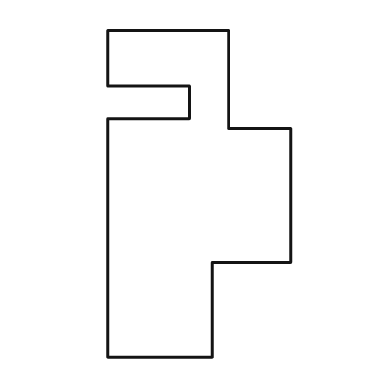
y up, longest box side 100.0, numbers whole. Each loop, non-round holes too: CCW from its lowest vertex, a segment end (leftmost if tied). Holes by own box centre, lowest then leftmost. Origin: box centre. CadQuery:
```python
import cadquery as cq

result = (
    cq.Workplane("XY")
    .moveTo(-28.0, -50.0)
    .lineTo(4.0, -50.0)
    .lineTo(4.0, -21.0)
    .lineTo(28.0, -21.0)
    .lineTo(28.0, 20.0)
    .lineTo(9.0, 20.0)
    .lineTo(9.0, 50.0)
    .lineTo(-28.0, 50.0)
    .lineTo(-28.0, 33.0)
    .lineTo(-3.0, 33.0)
    .lineTo(-3.0, 23.0)
    .lineTo(-28.0, 23.0)
    .close()
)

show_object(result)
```